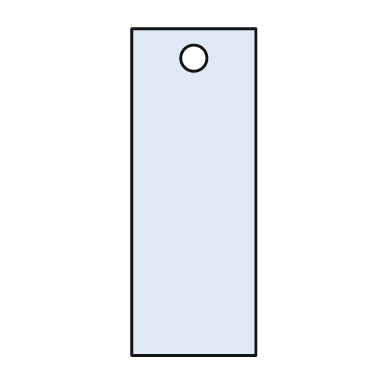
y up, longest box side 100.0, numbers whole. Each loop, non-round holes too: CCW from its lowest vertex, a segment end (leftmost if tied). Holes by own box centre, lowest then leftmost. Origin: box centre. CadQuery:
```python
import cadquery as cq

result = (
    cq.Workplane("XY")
    .moveTo(-19.0, -50.0)
    .lineTo(19.0, -50.0)
    .lineTo(19.0, 50.0)
    .lineTo(-19.0, 50.0)
    .close()
    .moveTo(0.0, 41.0)
    .circle(4.0)
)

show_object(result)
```